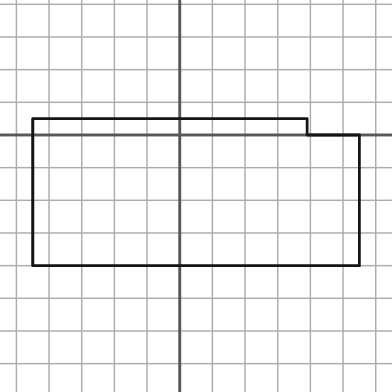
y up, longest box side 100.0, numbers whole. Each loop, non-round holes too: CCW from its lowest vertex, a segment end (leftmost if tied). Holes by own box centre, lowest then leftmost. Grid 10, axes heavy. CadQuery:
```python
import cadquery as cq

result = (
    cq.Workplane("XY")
    .moveTo(-45.0, -40.0)
    .lineTo(55.0, -40.0)
    .lineTo(55.0, 0.0)
    .lineTo(39.0, 0.0)
    .lineTo(39.0, 5.0)
    .lineTo(-45.0, 5.0)
    .close()
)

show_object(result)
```